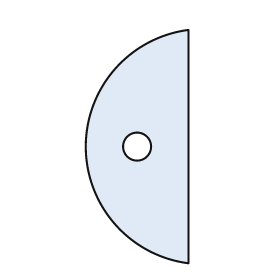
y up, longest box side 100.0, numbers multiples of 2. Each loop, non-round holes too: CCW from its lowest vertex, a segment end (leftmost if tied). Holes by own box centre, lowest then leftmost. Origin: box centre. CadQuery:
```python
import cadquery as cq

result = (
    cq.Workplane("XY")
    .moveTo(22.0, -50.0)
    .lineTo(22.0, 50.0)
    .threePointArc((-22.0, 0.0), (22.0, -50.0))
    .close()
    .moveTo(0.0, 0.0)
    .circle(6.0)
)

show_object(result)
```